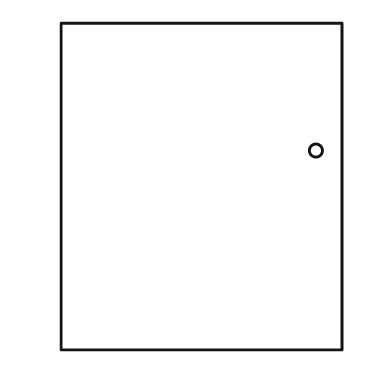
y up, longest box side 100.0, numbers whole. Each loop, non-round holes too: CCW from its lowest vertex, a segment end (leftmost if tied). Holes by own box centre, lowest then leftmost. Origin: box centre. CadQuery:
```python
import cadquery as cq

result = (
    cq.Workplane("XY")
    .moveTo(-43.0, -50.0)
    .lineTo(43.0, -50.0)
    .lineTo(43.0, 50.0)
    .lineTo(-43.0, 50.0)
    .close()
    .moveTo(35.0, 11.0)
    .circle(2.0)
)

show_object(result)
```